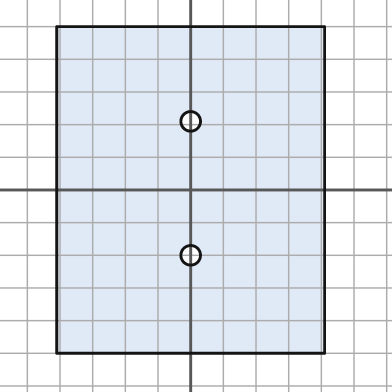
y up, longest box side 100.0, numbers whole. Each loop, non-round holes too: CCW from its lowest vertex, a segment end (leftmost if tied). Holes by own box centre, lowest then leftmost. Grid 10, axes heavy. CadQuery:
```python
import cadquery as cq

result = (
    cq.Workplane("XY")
    .moveTo(-41.0, -50.0)
    .lineTo(41.0, -50.0)
    .lineTo(41.0, 50.0)
    .lineTo(-41.0, 50.0)
    .close()
    .moveTo(0.0, -20.0)
    .circle(3.0)
    .moveTo(0.0, 21.0)
    .circle(3.0)
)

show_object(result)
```